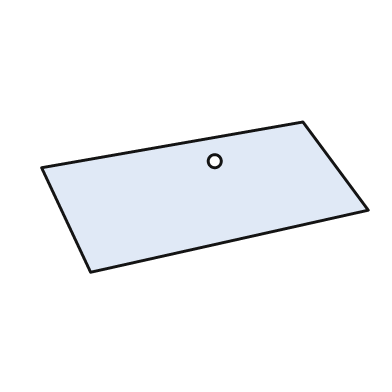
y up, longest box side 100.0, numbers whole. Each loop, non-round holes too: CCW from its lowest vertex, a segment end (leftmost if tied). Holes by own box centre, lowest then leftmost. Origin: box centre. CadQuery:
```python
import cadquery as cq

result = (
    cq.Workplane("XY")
    .moveTo(-35.0, -23.0)
    .lineTo(50.0, -4.0)
    .lineTo(30.0, 23.0)
    .lineTo(-50.0, 9.0)
    .close()
    .moveTo(3.0, 11.0)
    .circle(2.0)
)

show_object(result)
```